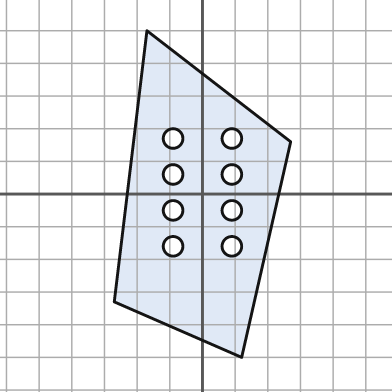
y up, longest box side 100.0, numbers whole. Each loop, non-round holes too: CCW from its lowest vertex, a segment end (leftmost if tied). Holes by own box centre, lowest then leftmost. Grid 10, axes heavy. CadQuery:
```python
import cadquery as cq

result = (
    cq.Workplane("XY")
    .moveTo(12.0, -50.0)
    .lineTo(27.0, 16.0)
    .lineTo(-17.0, 50.0)
    .lineTo(-27.0, -33.0)
    .close()
    .moveTo(-9.0, -16.0)
    .circle(3.0)
    .moveTo(9.0, -16.0)
    .circle(3.0)
    .moveTo(-9.0, -5.0)
    .circle(3.0)
    .moveTo(9.0, -5.0)
    .circle(3.0)
    .moveTo(-9.0, 6.0)
    .circle(3.0)
    .moveTo(9.0, 6.0)
    .circle(3.0)
    .moveTo(-9.0, 17.0)
    .circle(3.0)
    .moveTo(9.0, 17.0)
    .circle(3.0)
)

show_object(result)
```